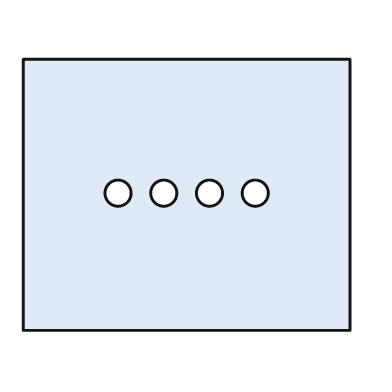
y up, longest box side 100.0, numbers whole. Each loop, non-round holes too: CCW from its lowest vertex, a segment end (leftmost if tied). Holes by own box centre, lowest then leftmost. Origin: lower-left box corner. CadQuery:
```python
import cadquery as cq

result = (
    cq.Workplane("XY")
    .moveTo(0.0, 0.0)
    .lineTo(100.0, 0.0)
    .lineTo(100.0, 83.0)
    .lineTo(0.0, 83.0)
    .close()
    .moveTo(29.0, 42.0)
    .circle(4.0)
    .moveTo(43.0, 42.0)
    .circle(4.0)
    .moveTo(57.0, 42.0)
    .circle(4.0)
    .moveTo(71.0, 42.0)
    .circle(4.0)
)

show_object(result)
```